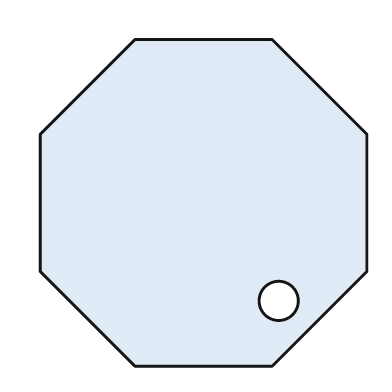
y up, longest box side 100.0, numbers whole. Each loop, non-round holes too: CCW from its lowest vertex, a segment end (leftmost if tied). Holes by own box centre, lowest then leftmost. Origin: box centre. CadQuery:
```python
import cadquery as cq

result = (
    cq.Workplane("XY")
    .moveTo(-21.0, -50.0)
    .lineTo(21.0, -50.0)
    .lineTo(50.0, -21.0)
    .lineTo(50.0, 21.0)
    .lineTo(21.0, 50.0)
    .lineTo(-21.0, 50.0)
    .lineTo(-50.0, 21.0)
    .lineTo(-50.0, -21.0)
    .close()
    .moveTo(23.0, -30.0)
    .circle(6.0)
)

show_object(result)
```